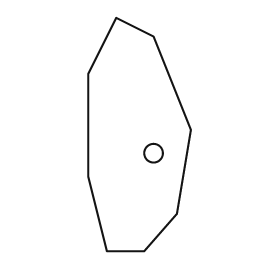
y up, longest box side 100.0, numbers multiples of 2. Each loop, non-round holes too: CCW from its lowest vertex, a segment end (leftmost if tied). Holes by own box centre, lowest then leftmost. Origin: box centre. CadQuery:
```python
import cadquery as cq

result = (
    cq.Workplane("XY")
    .moveTo(-14.0, -50.0)
    .lineTo(2.0, -50.0)
    .lineTo(16.0, -34.0)
    .lineTo(22.0, 2.0)
    .lineTo(6.0, 42.0)
    .lineTo(-10.0, 50.0)
    .lineTo(-22.0, 26.0)
    .lineTo(-22.0, -18.0)
    .close()
    .moveTo(6.0, -8.0)
    .circle(4.0)
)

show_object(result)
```